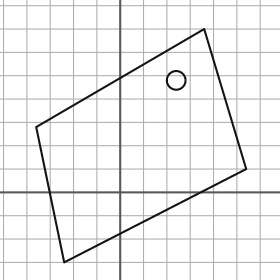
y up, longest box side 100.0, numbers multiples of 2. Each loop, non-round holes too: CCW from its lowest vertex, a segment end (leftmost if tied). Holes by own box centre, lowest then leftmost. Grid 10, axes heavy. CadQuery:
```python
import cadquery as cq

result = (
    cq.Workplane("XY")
    .moveTo(-24.0, -30.0)
    .lineTo(54.0, 10.0)
    .lineTo(36.0, 70.0)
    .lineTo(-36.0, 28.0)
    .close()
    .moveTo(24.0, 48.0)
    .circle(4.0)
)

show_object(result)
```